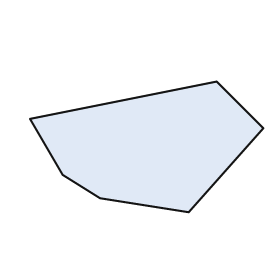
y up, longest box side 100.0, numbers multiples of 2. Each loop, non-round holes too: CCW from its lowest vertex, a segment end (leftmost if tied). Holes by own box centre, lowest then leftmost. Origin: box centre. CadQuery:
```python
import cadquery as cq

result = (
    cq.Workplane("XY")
    .moveTo(18.0, -28.0)
    .lineTo(50.0, 8.0)
    .lineTo(30.0, 28.0)
    .lineTo(-50.0, 12.0)
    .lineTo(-36.0, -12.0)
    .lineTo(-20.0, -22.0)
    .close()
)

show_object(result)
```